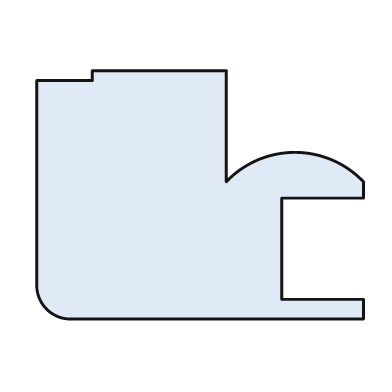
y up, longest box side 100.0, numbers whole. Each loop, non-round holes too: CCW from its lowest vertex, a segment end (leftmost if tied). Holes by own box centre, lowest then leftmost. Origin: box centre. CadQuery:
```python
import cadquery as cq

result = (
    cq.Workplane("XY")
    .moveTo(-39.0, -38.0)
    .lineTo(50.0, -38.0)
    .lineTo(50.0, -32.0)
    .lineTo(25.0, -32.0)
    .lineTo(25.0, -1.0)
    .lineTo(50.0, -1.0)
    .lineTo(50.0, 4.0)
    .threePointArc((29.0, 13.0), (8.0, 4.0))
    .lineTo(8.0, 38.0)
    .lineTo(-33.0, 38.0)
    .lineTo(-33.0, 35.0)
    .lineTo(-50.0, 35.0)
    .lineTo(-50.0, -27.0)
    .threePointArc((-47.0, -35.0), (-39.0, -38.0))
    .close()
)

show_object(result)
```